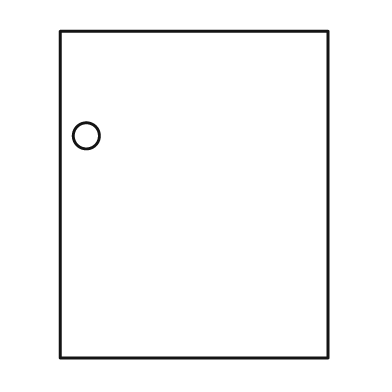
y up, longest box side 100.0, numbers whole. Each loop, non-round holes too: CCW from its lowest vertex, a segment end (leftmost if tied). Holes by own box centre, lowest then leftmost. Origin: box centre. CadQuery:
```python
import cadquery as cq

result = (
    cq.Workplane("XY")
    .moveTo(-41.0, -50.0)
    .lineTo(41.0, -50.0)
    .lineTo(41.0, 50.0)
    .lineTo(-41.0, 50.0)
    .close()
    .moveTo(-33.0, 18.0)
    .circle(4.0)
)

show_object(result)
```